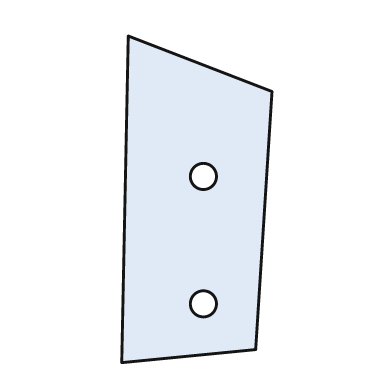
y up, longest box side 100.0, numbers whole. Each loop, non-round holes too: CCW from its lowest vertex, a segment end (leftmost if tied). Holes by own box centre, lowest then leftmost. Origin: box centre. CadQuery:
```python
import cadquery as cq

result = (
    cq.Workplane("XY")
    .moveTo(-23.0, -50.0)
    .lineTo(18.0, -46.0)
    .lineTo(23.0, 33.0)
    .lineTo(-21.0, 50.0)
    .close()
    .moveTo(2.0, -32.0)
    .circle(4.0)
    .moveTo(2.0, 7.0)
    .circle(4.0)
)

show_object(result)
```